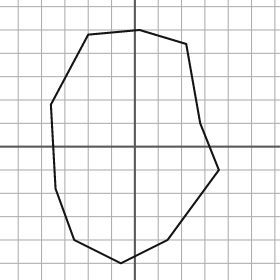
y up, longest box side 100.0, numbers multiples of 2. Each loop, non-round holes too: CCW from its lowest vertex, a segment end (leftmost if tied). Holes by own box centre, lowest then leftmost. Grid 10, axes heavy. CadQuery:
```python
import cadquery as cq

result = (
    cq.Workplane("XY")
    .moveTo(-6.0, -50.0)
    .lineTo(14.0, -40.0)
    .lineTo(36.0, -10.0)
    .lineTo(28.0, 10.0)
    .lineTo(22.0, 44.0)
    .lineTo(2.0, 50.0)
    .lineTo(-20.0, 48.0)
    .lineTo(-36.0, 18.0)
    .lineTo(-34.0, -18.0)
    .lineTo(-26.0, -40.0)
    .close()
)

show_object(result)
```